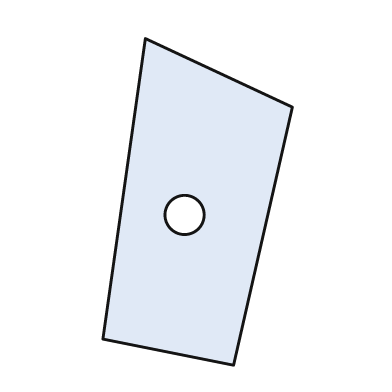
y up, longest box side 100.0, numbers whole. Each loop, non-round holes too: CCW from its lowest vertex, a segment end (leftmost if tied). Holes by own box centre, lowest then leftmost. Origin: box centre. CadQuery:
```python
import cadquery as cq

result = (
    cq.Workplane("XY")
    .moveTo(11.0, -50.0)
    .lineTo(29.0, 29.0)
    .lineTo(-16.0, 50.0)
    .lineTo(-29.0, -42.0)
    .close()
    .moveTo(-4.0, -4.0)
    .circle(6.0)
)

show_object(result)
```